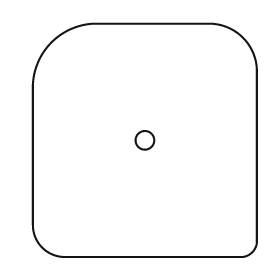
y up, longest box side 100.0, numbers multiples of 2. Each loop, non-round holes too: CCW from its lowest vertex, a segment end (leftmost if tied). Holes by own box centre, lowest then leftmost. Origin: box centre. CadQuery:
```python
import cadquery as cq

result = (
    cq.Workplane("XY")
    .moveTo(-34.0, -50.0)
    .lineTo(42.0, -50.0)
    .threePointArc((46.0, -48.0), (48.0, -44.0))
    .lineTo(48.0, 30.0)
    .threePointArc((42.0, 44.0), (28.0, 50.0))
    .lineTo(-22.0, 50.0)
    .threePointArc((-40.0, 42.0), (-48.0, 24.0))
    .lineTo(-48.0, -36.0)
    .threePointArc((-44.0, -46.0), (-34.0, -50.0))
    .close()
    .moveTo(0.0, 0.0)
    .circle(4.0)
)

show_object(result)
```